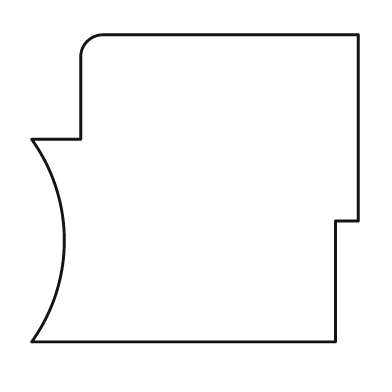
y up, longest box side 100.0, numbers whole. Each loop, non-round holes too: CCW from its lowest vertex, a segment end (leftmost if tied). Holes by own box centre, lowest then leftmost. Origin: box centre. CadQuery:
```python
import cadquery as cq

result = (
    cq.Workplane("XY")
    .moveTo(-50.0, -47.0)
    .lineTo(43.0, -47.0)
    .lineTo(43.0, -10.0)
    .lineTo(50.0, -10.0)
    .lineTo(50.0, 47.0)
    .lineTo(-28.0, 47.0)
    .threePointArc((-33.0, 45.0), (-35.0, 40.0))
    .lineTo(-35.0, 15.0)
    .lineTo(-50.0, 15.0)
    .threePointArc((-40.0, -16.0), (-50.0, -47.0))
    .close()
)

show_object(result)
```